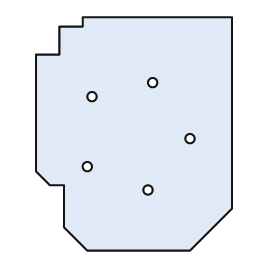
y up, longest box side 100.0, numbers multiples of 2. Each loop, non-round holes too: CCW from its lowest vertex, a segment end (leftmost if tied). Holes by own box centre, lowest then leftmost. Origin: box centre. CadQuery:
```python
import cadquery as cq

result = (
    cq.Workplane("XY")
    .moveTo(-20.0, -50.0)
    .lineTo(24.0, -50.0)
    .lineTo(42.0, -32.0)
    .lineTo(42.0, 50.0)
    .lineTo(-22.0, 50.0)
    .lineTo(-22.0, 46.0)
    .lineTo(-32.0, 46.0)
    .lineTo(-32.0, 34.0)
    .lineTo(-42.0, 34.0)
    .lineTo(-42.0, -16.0)
    .lineTo(-36.0, -22.0)
    .lineTo(-30.0, -22.0)
    .lineTo(-30.0, -40.0)
    .close()
    .moveTo(6.0, -24.0)
    .circle(2.0)
    .moveTo(-20.0, -14.0)
    .circle(2.0)
    .moveTo(24.0, -2.0)
    .circle(2.0)
    .moveTo(-18.0, 16.0)
    .circle(2.0)
    .moveTo(8.0, 22.0)
    .circle(2.0)
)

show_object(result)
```